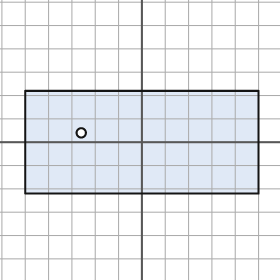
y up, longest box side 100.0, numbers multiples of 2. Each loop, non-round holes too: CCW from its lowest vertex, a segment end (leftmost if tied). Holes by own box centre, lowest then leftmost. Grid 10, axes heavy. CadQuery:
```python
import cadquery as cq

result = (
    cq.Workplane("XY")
    .moveTo(-50.0, -22.0)
    .lineTo(50.0, -22.0)
    .lineTo(50.0, 22.0)
    .lineTo(-50.0, 22.0)
    .close()
    .moveTo(-26.0, 4.0)
    .circle(2.0)
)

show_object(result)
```